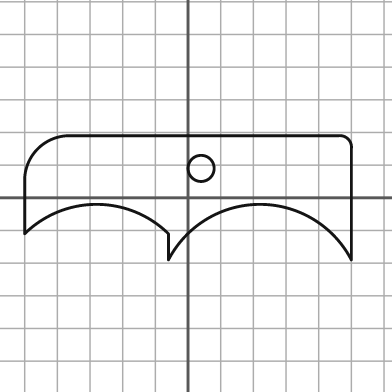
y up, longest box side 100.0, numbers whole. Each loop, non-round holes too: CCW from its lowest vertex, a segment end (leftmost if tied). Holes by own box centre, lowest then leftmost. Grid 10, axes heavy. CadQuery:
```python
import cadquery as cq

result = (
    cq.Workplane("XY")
    .moveTo(-6.0, -19.0)
    .threePointArc((22.0, -2.0), (50.0, -19.0))
    .lineTo(50.0, 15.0)
    .threePointArc((49.0, 18.0), (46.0, 19.0))
    .lineTo(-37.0, 19.0)
    .threePointArc((-46.0, 15.0), (-50.0, 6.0))
    .lineTo(-50.0, -11.0)
    .threePointArc((-28.0, -2.0), (-6.0, -11.0))
    .close()
    .moveTo(4.0, 9.0)
    .circle(4.0)
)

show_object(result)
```